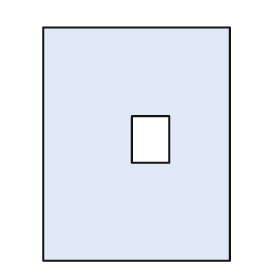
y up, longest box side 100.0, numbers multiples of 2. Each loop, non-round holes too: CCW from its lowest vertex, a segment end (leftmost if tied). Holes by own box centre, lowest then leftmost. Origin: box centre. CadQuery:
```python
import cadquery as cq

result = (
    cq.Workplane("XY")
    .moveTo(-40.0, -50.0)
    .lineTo(40.0, -50.0)
    .lineTo(40.0, 50.0)
    .lineTo(-40.0, 50.0)
    .close()
    .moveTo(-2.0, -8.0)
    .lineTo(14.0, -8.0)
    .lineTo(14.0, 12.0)
    .lineTo(-2.0, 12.0)
    .close()
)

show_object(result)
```